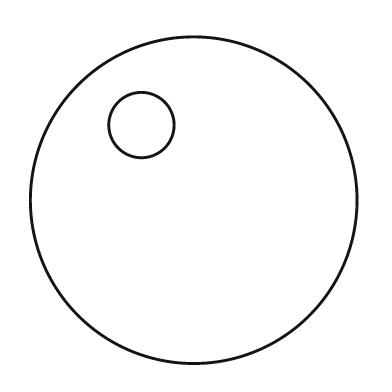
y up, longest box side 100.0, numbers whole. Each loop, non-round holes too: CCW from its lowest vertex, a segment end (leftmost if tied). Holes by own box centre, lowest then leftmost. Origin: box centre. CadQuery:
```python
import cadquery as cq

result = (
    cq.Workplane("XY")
    .moveTo(0.0, 0.0)
    .circle(50.0)
    .moveTo(-16.0, 23.0)
    .circle(10.0)
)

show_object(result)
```